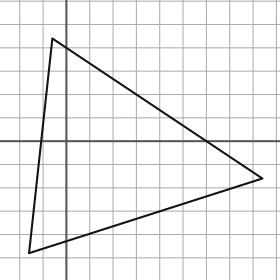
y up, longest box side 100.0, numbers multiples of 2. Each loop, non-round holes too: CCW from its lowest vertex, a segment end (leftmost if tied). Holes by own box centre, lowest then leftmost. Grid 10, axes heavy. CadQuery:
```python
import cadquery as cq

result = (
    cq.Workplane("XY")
    .moveTo(-16.0, -48.0)
    .lineTo(84.0, -16.0)
    .lineTo(-6.0, 44.0)
    .close()
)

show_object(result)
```